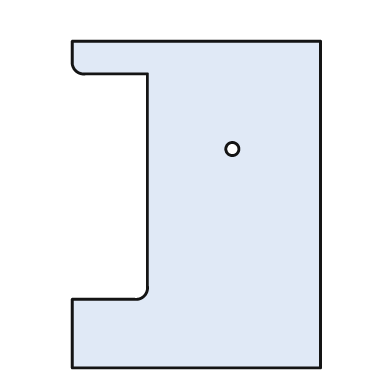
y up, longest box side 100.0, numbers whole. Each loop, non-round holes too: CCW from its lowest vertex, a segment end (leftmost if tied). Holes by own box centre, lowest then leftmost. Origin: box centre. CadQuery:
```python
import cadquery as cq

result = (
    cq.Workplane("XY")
    .moveTo(-38.0, -50.0)
    .lineTo(38.0, -50.0)
    .lineTo(38.0, 50.0)
    .lineTo(-38.0, 50.0)
    .lineTo(-38.0, 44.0)
    .threePointArc((-37.0, 41.0), (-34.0, 40.0))
    .lineTo(-15.0, 40.0)
    .lineTo(-15.0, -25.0)
    .threePointArc((-16.0, -28.0), (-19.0, -29.0))
    .lineTo(-38.0, -29.0)
    .close()
    .moveTo(11.0, 17.0)
    .circle(2.0)
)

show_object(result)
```